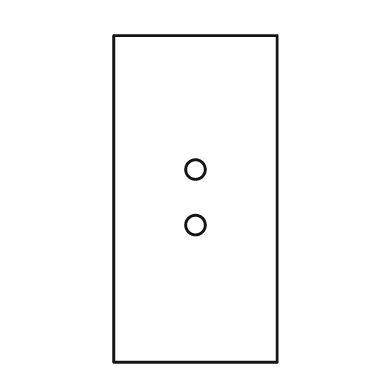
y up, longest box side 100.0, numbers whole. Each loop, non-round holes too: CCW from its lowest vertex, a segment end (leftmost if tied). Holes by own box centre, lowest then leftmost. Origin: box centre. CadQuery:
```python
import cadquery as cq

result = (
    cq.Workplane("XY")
    .moveTo(-25.0, -50.0)
    .lineTo(25.0, -50.0)
    .lineTo(25.0, 50.0)
    .lineTo(-25.0, 50.0)
    .close()
    .moveTo(0.0, -8.0)
    .circle(3.0)
    .moveTo(0.0, 9.0)
    .circle(3.0)
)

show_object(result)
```